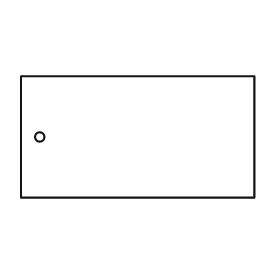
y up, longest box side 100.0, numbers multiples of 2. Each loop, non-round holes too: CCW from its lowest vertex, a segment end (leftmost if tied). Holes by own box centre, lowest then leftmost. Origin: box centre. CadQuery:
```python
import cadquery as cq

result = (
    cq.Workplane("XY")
    .moveTo(-50.0, -26.0)
    .lineTo(50.0, -26.0)
    .lineTo(50.0, 26.0)
    .lineTo(-50.0, 26.0)
    .close()
    .moveTo(-42.0, 0.0)
    .circle(2.0)
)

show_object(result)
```